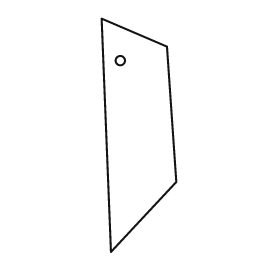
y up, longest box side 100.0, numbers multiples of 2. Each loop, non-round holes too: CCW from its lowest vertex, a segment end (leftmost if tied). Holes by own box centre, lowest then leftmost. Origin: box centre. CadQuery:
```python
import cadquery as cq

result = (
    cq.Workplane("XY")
    .moveTo(-12.0, -50.0)
    .lineTo(16.0, -20.0)
    .lineTo(12.0, 38.0)
    .lineTo(-16.0, 50.0)
    .close()
    .moveTo(-8.0, 32.0)
    .circle(2.0)
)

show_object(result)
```